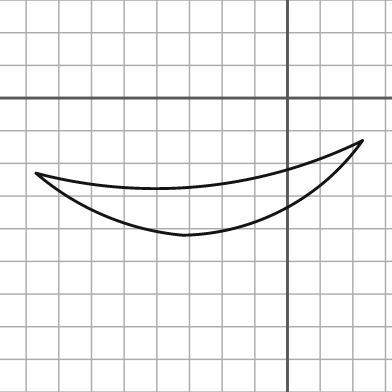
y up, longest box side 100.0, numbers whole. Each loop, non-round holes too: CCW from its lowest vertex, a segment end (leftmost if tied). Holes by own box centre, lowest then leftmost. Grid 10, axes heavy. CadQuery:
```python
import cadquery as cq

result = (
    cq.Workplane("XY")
    .moveTo(-32.0, -42.0)
    .threePointArc((-1.0, -34.0), (23.0, -13.0))
    .threePointArc((-26.0, -27.0), (-77.0, -23.0))
    .threePointArc((-56.0, -36.0), (-32.0, -42.0))
    .close()
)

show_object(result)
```